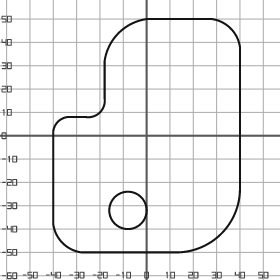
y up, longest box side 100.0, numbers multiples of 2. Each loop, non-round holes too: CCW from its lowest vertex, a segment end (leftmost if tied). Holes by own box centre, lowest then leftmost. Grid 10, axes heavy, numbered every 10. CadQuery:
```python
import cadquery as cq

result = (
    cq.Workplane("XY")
    .moveTo(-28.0, -50.0)
    .lineTo(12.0, -50.0)
    .threePointArc((32.0, -42.0), (40.0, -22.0))
    .lineTo(40.0, 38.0)
    .threePointArc((36.0, 46.0), (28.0, 50.0))
    .lineTo(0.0, 50.0)
    .threePointArc((-12.0, 44.0), (-18.0, 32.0))
    .lineTo(-18.0, 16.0)
    .threePointArc((-20.0, 10.0), (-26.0, 8.0))
    .lineTo(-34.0, 8.0)
    .threePointArc((-38.0, 6.0), (-40.0, 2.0))
    .lineTo(-40.0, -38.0)
    .threePointArc((-36.0, -46.0), (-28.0, -50.0))
    .close()
    .moveTo(-8.0, -32.0)
    .circle(8.0)
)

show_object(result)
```